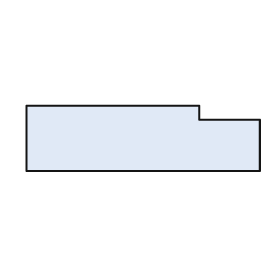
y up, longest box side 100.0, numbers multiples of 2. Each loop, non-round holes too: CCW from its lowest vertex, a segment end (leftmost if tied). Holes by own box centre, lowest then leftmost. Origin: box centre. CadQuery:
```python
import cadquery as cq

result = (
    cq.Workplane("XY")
    .moveTo(-50.0, -14.0)
    .lineTo(50.0, -14.0)
    .lineTo(50.0, 8.0)
    .lineTo(24.0, 8.0)
    .lineTo(24.0, 14.0)
    .lineTo(-50.0, 14.0)
    .close()
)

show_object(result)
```